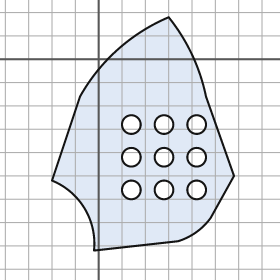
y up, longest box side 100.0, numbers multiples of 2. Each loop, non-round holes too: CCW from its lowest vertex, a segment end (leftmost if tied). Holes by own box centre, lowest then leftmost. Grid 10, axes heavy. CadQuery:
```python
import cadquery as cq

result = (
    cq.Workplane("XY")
    .moveTo(-2.0, -82.0)
    .lineTo(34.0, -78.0)
    .threePointArc((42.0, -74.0), (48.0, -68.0))
    .lineTo(58.0, -50.0)
    .lineTo(46.0, -16.0)
    .threePointArc((40.0, 2.0), (30.0, 18.0))
    .threePointArc((8.0, 4.0), (-8.0, -16.0))
    .lineTo(-20.0, -52.0)
    .threePointArc((-6.0, -64.0), (-2.0, -82.0))
    .close()
    .moveTo(14.0, -56.0)
    .circle(4.0)
    .moveTo(28.0, -56.0)
    .circle(4.0)
    .moveTo(42.0, -56.0)
    .circle(4.0)
    .moveTo(14.0, -42.0)
    .circle(4.0)
    .moveTo(28.0, -42.0)
    .circle(4.0)
    .moveTo(42.0, -42.0)
    .circle(4.0)
    .moveTo(14.0, -28.0)
    .circle(4.0)
    .moveTo(28.0, -28.0)
    .circle(4.0)
    .moveTo(42.0, -28.0)
    .circle(4.0)
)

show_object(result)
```